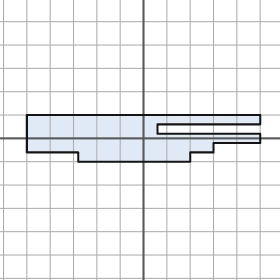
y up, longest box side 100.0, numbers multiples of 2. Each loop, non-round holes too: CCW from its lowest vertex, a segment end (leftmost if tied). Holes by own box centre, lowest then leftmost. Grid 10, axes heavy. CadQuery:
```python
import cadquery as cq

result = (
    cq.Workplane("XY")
    .moveTo(-28.0, -10.0)
    .lineTo(20.0, -10.0)
    .lineTo(20.0, -6.0)
    .lineTo(30.0, -6.0)
    .lineTo(30.0, -2.0)
    .lineTo(50.0, -2.0)
    .lineTo(50.0, 2.0)
    .lineTo(6.0, 2.0)
    .lineTo(6.0, 6.0)
    .lineTo(50.0, 6.0)
    .lineTo(50.0, 10.0)
    .lineTo(-50.0, 10.0)
    .lineTo(-50.0, -6.0)
    .lineTo(-28.0, -6.0)
    .close()
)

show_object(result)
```